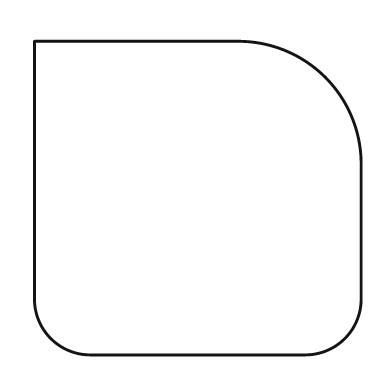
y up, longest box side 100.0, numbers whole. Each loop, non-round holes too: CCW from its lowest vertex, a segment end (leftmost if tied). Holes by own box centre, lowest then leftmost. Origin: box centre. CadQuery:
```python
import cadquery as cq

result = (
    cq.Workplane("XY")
    .moveTo(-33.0, -48.0)
    .lineTo(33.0, -48.0)
    .threePointArc((45.0, -43.0), (50.0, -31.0))
    .lineTo(50.0, 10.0)
    .threePointArc((39.0, 37.0), (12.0, 48.0))
    .lineTo(-50.0, 48.0)
    .lineTo(-50.0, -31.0)
    .threePointArc((-45.0, -43.0), (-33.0, -48.0))
    .close()
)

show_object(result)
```